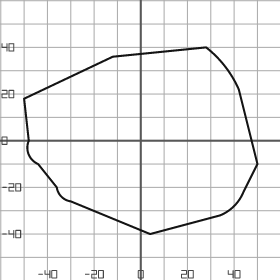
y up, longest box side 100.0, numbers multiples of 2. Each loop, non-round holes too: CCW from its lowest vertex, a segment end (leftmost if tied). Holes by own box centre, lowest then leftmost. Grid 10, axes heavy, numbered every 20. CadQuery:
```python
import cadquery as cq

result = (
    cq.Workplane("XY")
    .moveTo(4.0, -40.0)
    .lineTo(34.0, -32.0)
    .threePointArc((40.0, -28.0), (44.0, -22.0))
    .lineTo(50.0, -10.0)
    .lineTo(42.0, 22.0)
    .threePointArc((36.0, 32.0), (28.0, 40.0))
    .lineTo(-12.0, 36.0)
    .lineTo(-50.0, 18.0)
    .lineTo(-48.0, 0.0)
    .threePointArc((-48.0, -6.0), (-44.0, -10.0))
    .lineTo(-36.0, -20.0)
    .threePointArc((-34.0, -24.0), (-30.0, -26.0))
    .close()
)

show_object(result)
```